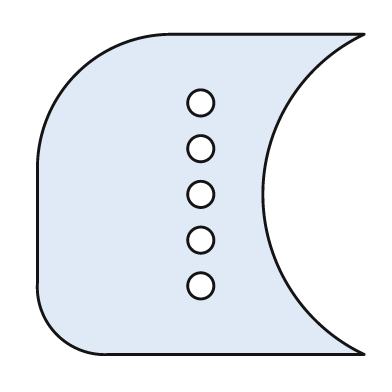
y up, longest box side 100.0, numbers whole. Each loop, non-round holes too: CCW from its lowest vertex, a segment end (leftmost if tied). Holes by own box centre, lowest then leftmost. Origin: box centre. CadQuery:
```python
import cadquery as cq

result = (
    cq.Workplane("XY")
    .moveTo(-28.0, -49.0)
    .lineTo(50.0, -49.0)
    .threePointArc((19.0, 0.0), (50.0, 49.0))
    .lineTo(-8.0, 49.0)
    .threePointArc((-38.0, 37.0), (-50.0, 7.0))
    .lineTo(-50.0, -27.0)
    .threePointArc((-44.0, -43.0), (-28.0, -49.0))
    .close()
    .moveTo(0.0, -28.0)
    .circle(4.0)
    .moveTo(0.0, -14.0)
    .circle(4.0)
    .moveTo(0.0, 0.0)
    .circle(4.0)
    .moveTo(0.0, 14.0)
    .circle(4.0)
    .moveTo(0.0, 28.0)
    .circle(4.0)
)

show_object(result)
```